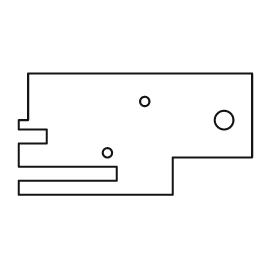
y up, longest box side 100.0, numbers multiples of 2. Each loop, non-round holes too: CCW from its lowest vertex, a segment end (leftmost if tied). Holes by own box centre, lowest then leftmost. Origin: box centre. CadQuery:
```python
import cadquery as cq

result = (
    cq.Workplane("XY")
    .moveTo(-50.0, -26.0)
    .lineTo(16.0, -26.0)
    .lineTo(16.0, -10.0)
    .lineTo(50.0, -10.0)
    .lineTo(50.0, 26.0)
    .lineTo(-46.0, 26.0)
    .lineTo(-46.0, 6.0)
    .lineTo(-50.0, 6.0)
    .lineTo(-50.0, 2.0)
    .lineTo(-38.0, 2.0)
    .lineTo(-38.0, -4.0)
    .lineTo(-50.0, -4.0)
    .lineTo(-50.0, -14.0)
    .lineTo(-8.0, -14.0)
    .lineTo(-8.0, -20.0)
    .lineTo(-50.0, -20.0)
    .close()
    .moveTo(-12.0, -8.0)
    .circle(2.0)
    .moveTo(38.0, 6.0)
    .circle(4.0)
    .moveTo(4.0, 14.0)
    .circle(2.0)
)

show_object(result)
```